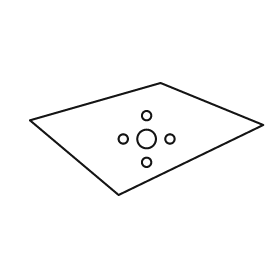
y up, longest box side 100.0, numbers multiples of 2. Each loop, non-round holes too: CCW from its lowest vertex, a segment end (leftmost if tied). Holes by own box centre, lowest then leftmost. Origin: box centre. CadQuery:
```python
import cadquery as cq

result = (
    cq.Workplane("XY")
    .moveTo(-12.0, -24.0)
    .lineTo(50.0, 6.0)
    .lineTo(6.0, 24.0)
    .lineTo(-50.0, 8.0)
    .close()
    .moveTo(0.0, -10.0)
    .circle(2.0)
    .moveTo(-10.0, 0.0)
    .circle(2.0)
    .moveTo(0.0, 0.0)
    .circle(4.0)
    .moveTo(10.0, 0.0)
    .circle(2.0)
    .moveTo(0.0, 10.0)
    .circle(2.0)
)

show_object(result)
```